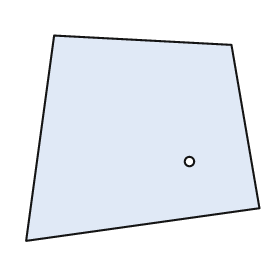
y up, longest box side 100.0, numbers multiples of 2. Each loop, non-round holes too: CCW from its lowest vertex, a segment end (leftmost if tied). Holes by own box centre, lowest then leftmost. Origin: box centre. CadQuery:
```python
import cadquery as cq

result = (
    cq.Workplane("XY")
    .moveTo(-50.0, -44.0)
    .lineTo(50.0, -30.0)
    .lineTo(38.0, 40.0)
    .lineTo(-38.0, 44.0)
    .close()
    .moveTo(20.0, -10.0)
    .circle(2.0)
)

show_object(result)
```